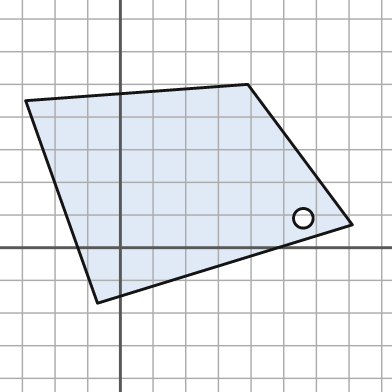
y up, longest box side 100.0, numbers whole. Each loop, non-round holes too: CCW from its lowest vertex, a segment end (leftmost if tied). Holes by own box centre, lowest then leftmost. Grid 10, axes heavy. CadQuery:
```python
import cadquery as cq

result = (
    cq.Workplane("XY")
    .moveTo(-7.0, -17.0)
    .lineTo(71.0, 7.0)
    .lineTo(39.0, 50.0)
    .lineTo(-29.0, 45.0)
    .close()
    .moveTo(56.0, 9.0)
    .circle(3.0)
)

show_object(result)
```